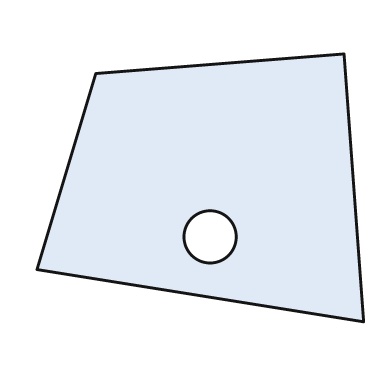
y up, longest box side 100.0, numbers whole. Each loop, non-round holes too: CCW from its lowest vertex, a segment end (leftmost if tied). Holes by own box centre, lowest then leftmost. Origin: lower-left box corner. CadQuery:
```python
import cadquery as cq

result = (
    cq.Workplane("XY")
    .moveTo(100.0, 0.0)
    .lineTo(94.0, 82.0)
    .lineTo(18.0, 76.0)
    .lineTo(0.0, 16.0)
    .close()
    .moveTo(53.0, 26.0)
    .circle(8.0)
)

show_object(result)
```